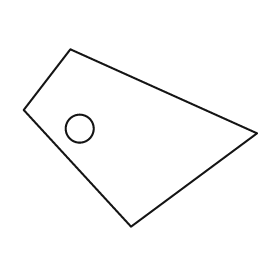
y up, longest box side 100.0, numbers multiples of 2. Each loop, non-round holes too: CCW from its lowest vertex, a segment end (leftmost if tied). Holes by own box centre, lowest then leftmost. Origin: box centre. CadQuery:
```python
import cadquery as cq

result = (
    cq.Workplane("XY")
    .moveTo(-4.0, -38.0)
    .lineTo(50.0, 2.0)
    .lineTo(-30.0, 38.0)
    .lineTo(-50.0, 12.0)
    .close()
    .moveTo(-26.0, 4.0)
    .circle(6.0)
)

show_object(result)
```